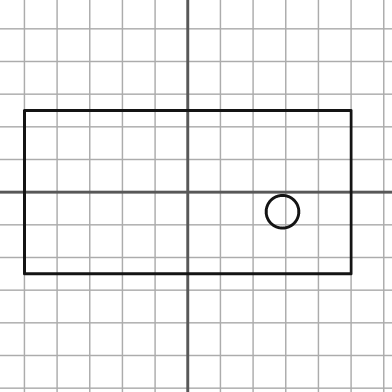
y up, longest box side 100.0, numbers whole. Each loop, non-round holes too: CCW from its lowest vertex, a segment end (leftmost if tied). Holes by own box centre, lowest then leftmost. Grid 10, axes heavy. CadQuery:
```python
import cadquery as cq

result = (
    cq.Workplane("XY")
    .moveTo(-50.0, -25.0)
    .lineTo(50.0, -25.0)
    .lineTo(50.0, 25.0)
    .lineTo(-50.0, 25.0)
    .close()
    .moveTo(29.0, -6.0)
    .circle(5.0)
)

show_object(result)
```